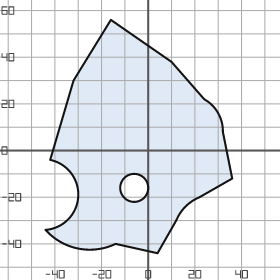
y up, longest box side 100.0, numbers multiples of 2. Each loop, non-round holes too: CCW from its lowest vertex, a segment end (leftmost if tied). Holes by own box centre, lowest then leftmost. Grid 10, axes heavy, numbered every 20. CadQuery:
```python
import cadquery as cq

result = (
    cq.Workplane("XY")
    .moveTo(4.0, -44.0)
    .lineTo(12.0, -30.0)
    .threePointArc((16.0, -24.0), (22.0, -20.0))
    .lineTo(36.0, -12.0)
    .lineTo(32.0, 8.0)
    .threePointArc((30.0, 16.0), (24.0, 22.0))
    .lineTo(10.0, 38.0)
    .lineTo(-16.0, 56.0)
    .lineTo(-32.0, 30.0)
    .lineTo(-42.0, -4.0)
    .threePointArc((-30.0, -20.0), (-44.0, -34.0))
    .threePointArc((-30.0, -42.0), (-14.0, -40.0))
    .close()
    .moveTo(-6.0, -16.0)
    .circle(6.0)
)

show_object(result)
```